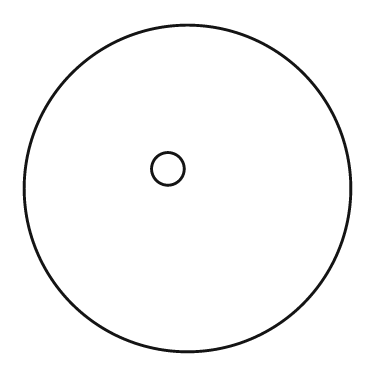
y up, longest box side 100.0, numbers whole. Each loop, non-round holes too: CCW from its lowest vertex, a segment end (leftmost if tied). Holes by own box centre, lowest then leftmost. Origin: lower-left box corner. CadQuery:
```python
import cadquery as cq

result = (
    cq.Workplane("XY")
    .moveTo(50.0, 50.0)
    .circle(50.0)
    .moveTo(44.0, 56.0)
    .circle(5.0)
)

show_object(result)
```